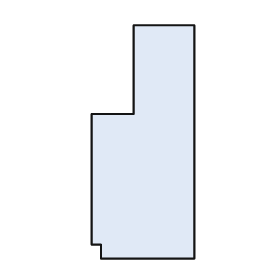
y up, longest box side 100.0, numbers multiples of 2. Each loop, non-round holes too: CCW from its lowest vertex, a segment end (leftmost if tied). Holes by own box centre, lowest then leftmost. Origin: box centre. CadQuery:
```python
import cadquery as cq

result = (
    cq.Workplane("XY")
    .moveTo(-18.0, -50.0)
    .lineTo(22.0, -50.0)
    .lineTo(22.0, 50.0)
    .lineTo(-4.0, 50.0)
    .lineTo(-4.0, 12.0)
    .lineTo(-22.0, 12.0)
    .lineTo(-22.0, -44.0)
    .lineTo(-18.0, -44.0)
    .close()
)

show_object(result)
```